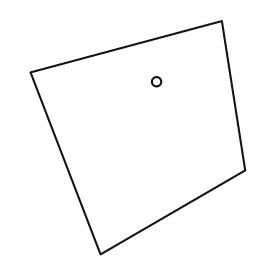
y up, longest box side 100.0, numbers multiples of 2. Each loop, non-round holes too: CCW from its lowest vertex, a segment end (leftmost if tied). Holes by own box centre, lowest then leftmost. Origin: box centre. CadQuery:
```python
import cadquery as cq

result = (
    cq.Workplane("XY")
    .moveTo(-16.0, -50.0)
    .lineTo(46.0, -14.0)
    .lineTo(36.0, 50.0)
    .lineTo(-46.0, 28.0)
    .close()
    .moveTo(8.0, 24.0)
    .circle(2.0)
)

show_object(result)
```